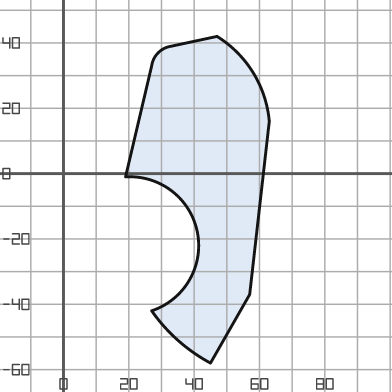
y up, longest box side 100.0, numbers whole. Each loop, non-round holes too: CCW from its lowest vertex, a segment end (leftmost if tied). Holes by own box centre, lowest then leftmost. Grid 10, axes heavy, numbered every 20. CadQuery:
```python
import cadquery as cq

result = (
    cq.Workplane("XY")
    .moveTo(45.0, -58.0)
    .lineTo(57.0, -37.0)
    .lineTo(63.0, 16.0)
    .threePointArc((58.0, 31.0), (47.0, 42.0))
    .lineTo(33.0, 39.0)
    .threePointArc((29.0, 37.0), (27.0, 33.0))
    .lineTo(19.0, -1.0)
    .threePointArc((41.0, -18.0), (27.0, -42.0))
    .threePointArc((35.0, -51.0), (45.0, -58.0))
    .close()
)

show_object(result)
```